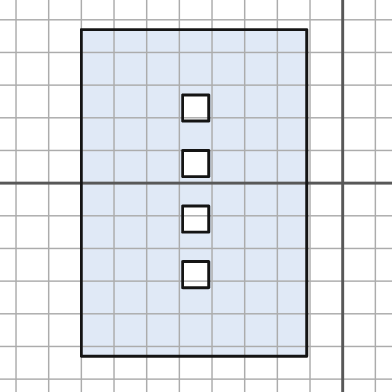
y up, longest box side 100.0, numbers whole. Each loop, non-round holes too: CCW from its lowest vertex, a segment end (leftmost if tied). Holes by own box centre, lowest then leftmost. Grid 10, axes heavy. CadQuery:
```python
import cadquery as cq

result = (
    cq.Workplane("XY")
    .moveTo(-80.0, -53.0)
    .lineTo(-11.0, -53.0)
    .lineTo(-11.0, 47.0)
    .lineTo(-80.0, 47.0)
    .close()
    .moveTo(-49.0, -32.0)
    .lineTo(-41.0, -32.0)
    .lineTo(-41.0, -24.0)
    .lineTo(-49.0, -24.0)
    .close()
    .moveTo(-49.0, -15.0)
    .lineTo(-41.0, -15.0)
    .lineTo(-41.0, -7.0)
    .lineTo(-49.0, -7.0)
    .close()
    .moveTo(-49.0, 2.0)
    .lineTo(-41.0, 2.0)
    .lineTo(-41.0, 10.0)
    .lineTo(-49.0, 10.0)
    .close()
    .moveTo(-49.0, 19.0)
    .lineTo(-41.0, 19.0)
    .lineTo(-41.0, 27.0)
    .lineTo(-49.0, 27.0)
    .close()
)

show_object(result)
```